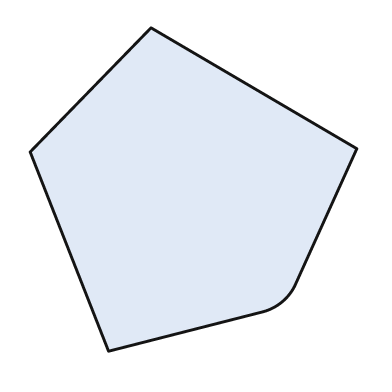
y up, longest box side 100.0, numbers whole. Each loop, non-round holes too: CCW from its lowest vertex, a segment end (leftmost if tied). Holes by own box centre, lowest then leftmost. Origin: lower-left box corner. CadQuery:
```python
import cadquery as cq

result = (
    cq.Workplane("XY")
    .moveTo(24.0, 0.0)
    .lineTo(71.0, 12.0)
    .threePointArc((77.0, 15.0), (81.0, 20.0))
    .lineTo(100.0, 62.0)
    .lineTo(37.0, 99.0)
    .lineTo(0.0, 61.0)
    .close()
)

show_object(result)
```